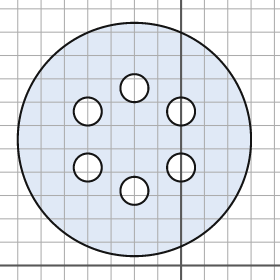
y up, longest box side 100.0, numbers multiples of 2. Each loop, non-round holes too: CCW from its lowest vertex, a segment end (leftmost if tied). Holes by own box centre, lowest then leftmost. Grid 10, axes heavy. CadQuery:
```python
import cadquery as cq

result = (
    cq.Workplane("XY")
    .moveTo(-20.0, 54.0)
    .circle(50.0)
    .moveTo(-20.0, 32.0)
    .circle(6.0)
    .moveTo(-40.0, 42.0)
    .circle(6.0)
    .moveTo(0.0, 42.0)
    .circle(6.0)
    .moveTo(-40.0, 66.0)
    .circle(6.0)
    .moveTo(0.0, 66.0)
    .circle(6.0)
    .moveTo(-20.0, 76.0)
    .circle(6.0)
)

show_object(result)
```